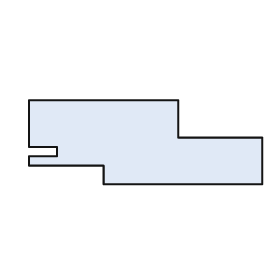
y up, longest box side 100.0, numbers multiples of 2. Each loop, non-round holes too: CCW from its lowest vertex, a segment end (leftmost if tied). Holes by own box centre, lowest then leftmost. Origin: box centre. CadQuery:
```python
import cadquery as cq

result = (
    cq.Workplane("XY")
    .moveTo(-18.0, -18.0)
    .lineTo(50.0, -18.0)
    .lineTo(50.0, 2.0)
    .lineTo(14.0, 2.0)
    .lineTo(14.0, 18.0)
    .lineTo(-50.0, 18.0)
    .lineTo(-50.0, -2.0)
    .lineTo(-38.0, -2.0)
    .lineTo(-38.0, -6.0)
    .lineTo(-50.0, -6.0)
    .lineTo(-50.0, -10.0)
    .lineTo(-18.0, -10.0)
    .close()
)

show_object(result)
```